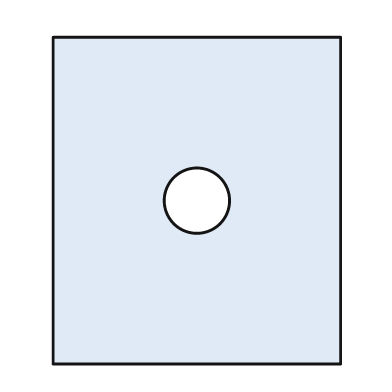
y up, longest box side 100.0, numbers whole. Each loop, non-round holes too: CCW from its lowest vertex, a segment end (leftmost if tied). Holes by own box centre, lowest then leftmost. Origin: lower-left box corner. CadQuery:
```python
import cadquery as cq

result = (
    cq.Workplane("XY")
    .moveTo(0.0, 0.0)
    .lineTo(88.0, 0.0)
    .lineTo(88.0, 100.0)
    .lineTo(0.0, 100.0)
    .close()
    .moveTo(44.0, 50.0)
    .circle(10.0)
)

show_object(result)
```